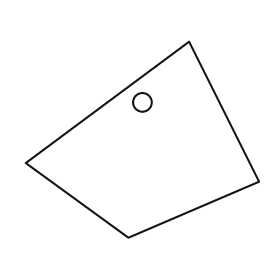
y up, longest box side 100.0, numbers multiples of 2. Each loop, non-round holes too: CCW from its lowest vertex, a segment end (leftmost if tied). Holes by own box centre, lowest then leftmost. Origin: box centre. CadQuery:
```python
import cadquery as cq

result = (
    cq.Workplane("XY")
    .moveTo(-6.0, -42.0)
    .lineTo(50.0, -18.0)
    .lineTo(20.0, 42.0)
    .lineTo(-50.0, -10.0)
    .close()
    .moveTo(0.0, 16.0)
    .circle(4.0)
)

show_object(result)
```